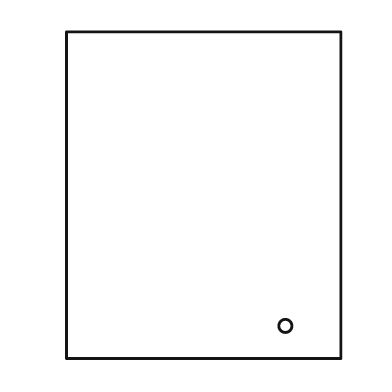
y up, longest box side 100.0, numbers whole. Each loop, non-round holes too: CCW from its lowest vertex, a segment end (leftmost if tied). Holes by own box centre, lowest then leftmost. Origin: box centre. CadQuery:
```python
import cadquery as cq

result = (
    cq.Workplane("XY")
    .moveTo(-42.0, -50.0)
    .lineTo(42.0, -50.0)
    .lineTo(42.0, 50.0)
    .lineTo(-42.0, 50.0)
    .close()
    .moveTo(25.0, -40.0)
    .circle(2.0)
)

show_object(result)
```